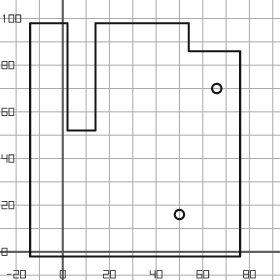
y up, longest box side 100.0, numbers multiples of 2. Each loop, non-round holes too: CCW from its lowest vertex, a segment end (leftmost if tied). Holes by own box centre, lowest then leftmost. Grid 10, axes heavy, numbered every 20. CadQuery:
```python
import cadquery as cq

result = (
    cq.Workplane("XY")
    .moveTo(-14.0, -2.0)
    .lineTo(76.0, -2.0)
    .lineTo(76.0, 86.0)
    .lineTo(54.0, 86.0)
    .lineTo(54.0, 98.0)
    .lineTo(14.0, 98.0)
    .lineTo(14.0, 52.0)
    .lineTo(2.0, 52.0)
    .lineTo(2.0, 98.0)
    .lineTo(-14.0, 98.0)
    .close()
    .moveTo(50.0, 16.0)
    .circle(2.0)
    .moveTo(66.0, 70.0)
    .circle(2.0)
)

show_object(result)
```